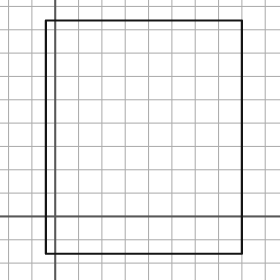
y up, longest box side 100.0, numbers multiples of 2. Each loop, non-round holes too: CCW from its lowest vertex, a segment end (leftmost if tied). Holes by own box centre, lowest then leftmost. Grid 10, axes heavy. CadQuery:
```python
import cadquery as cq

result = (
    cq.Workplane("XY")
    .moveTo(-4.0, -16.0)
    .lineTo(80.0, -16.0)
    .lineTo(80.0, 84.0)
    .lineTo(-4.0, 84.0)
    .close()
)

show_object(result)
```